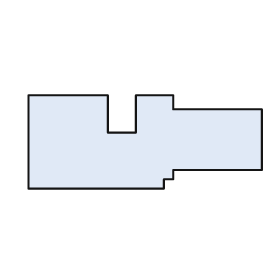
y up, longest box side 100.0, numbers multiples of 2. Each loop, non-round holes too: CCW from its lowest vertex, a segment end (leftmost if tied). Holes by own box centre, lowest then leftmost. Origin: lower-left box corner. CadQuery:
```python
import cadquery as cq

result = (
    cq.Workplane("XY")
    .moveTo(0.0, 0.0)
    .lineTo(58.0, 0.0)
    .lineTo(58.0, 4.0)
    .lineTo(62.0, 4.0)
    .lineTo(62.0, 8.0)
    .lineTo(100.0, 8.0)
    .lineTo(100.0, 34.0)
    .lineTo(62.0, 34.0)
    .lineTo(62.0, 40.0)
    .lineTo(46.0, 40.0)
    .lineTo(46.0, 24.0)
    .lineTo(34.0, 24.0)
    .lineTo(34.0, 40.0)
    .lineTo(0.0, 40.0)
    .close()
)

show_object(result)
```